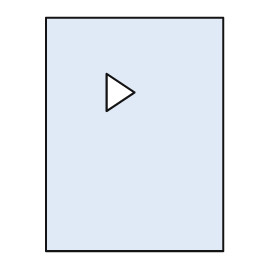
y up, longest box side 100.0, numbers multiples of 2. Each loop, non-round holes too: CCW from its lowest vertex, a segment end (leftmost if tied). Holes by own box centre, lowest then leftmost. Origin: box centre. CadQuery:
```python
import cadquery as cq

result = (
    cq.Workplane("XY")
    .moveTo(-38.0, -50.0)
    .lineTo(38.0, -50.0)
    .lineTo(38.0, 50.0)
    .lineTo(-38.0, 50.0)
    .close()
    .moveTo(-12.0, 10.0)
    .lineTo(0.0, 18.0)
    .lineTo(-12.0, 26.0)
    .close()
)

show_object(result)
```